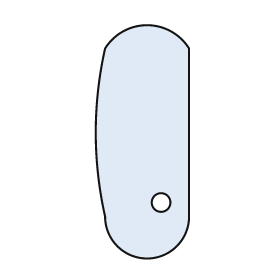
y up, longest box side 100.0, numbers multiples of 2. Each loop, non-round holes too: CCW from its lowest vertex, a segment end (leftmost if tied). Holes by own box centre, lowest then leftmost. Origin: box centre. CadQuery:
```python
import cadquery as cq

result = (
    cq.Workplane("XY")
    .moveTo(-16.0, -32.0)
    .threePointArc((2.0, -50.0), (20.0, -32.0))
    .lineTo(20.0, 40.0)
    .threePointArc((2.0, 50.0), (-16.0, 40.0))
    .threePointArc((-20.0, 4.0), (-16.0, -32.0))
    .close()
    .moveTo(8.0, -26.0)
    .circle(4.0)
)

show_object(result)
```